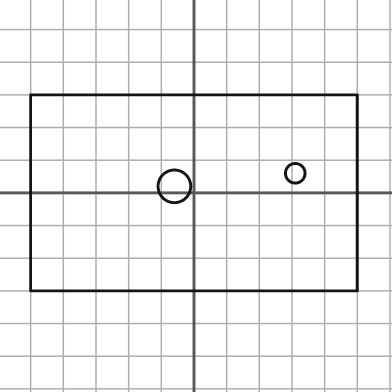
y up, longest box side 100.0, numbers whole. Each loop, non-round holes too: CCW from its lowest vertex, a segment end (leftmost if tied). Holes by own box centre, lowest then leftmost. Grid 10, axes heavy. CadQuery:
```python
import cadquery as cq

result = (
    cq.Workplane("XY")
    .moveTo(-50.0, -30.0)
    .lineTo(50.0, -30.0)
    .lineTo(50.0, 30.0)
    .lineTo(-50.0, 30.0)
    .close()
    .moveTo(-6.0, 2.0)
    .circle(5.0)
    .moveTo(31.0, 6.0)
    .circle(3.0)
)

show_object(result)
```